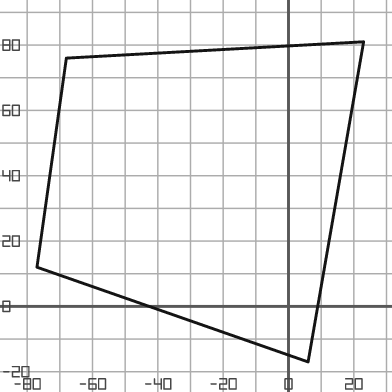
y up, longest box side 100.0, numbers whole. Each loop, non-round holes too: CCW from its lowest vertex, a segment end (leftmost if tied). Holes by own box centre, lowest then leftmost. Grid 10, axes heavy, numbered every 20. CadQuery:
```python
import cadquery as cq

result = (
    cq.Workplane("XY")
    .moveTo(6.0, -17.0)
    .lineTo(23.0, 81.0)
    .lineTo(-68.0, 76.0)
    .lineTo(-77.0, 12.0)
    .close()
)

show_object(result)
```